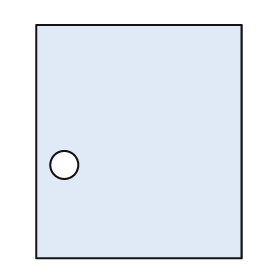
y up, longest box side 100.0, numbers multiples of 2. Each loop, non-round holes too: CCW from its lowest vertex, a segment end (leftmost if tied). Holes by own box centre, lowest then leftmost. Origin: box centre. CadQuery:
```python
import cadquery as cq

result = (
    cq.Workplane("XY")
    .moveTo(-44.0, -50.0)
    .lineTo(44.0, -50.0)
    .lineTo(44.0, 50.0)
    .lineTo(-44.0, 50.0)
    .close()
    .moveTo(-32.0, -10.0)
    .circle(6.0)
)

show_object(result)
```